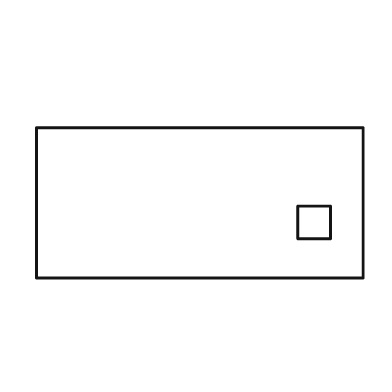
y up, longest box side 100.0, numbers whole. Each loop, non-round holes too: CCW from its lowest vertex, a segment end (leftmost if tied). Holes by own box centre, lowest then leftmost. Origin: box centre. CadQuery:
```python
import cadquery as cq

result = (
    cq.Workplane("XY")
    .moveTo(-50.0, -23.0)
    .lineTo(50.0, -23.0)
    .lineTo(50.0, 23.0)
    .lineTo(-50.0, 23.0)
    .close()
    .moveTo(30.0, -11.0)
    .lineTo(40.0, -11.0)
    .lineTo(40.0, -1.0)
    .lineTo(30.0, -1.0)
    .close()
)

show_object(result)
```